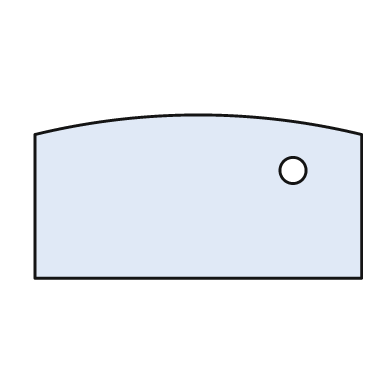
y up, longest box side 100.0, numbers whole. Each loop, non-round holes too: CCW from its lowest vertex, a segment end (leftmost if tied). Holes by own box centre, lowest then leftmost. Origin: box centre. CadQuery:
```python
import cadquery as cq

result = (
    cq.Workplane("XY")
    .moveTo(-50.0, -25.0)
    .lineTo(50.0, -25.0)
    .lineTo(50.0, 19.0)
    .threePointArc((0.0, 25.0), (-50.0, 19.0))
    .close()
    .moveTo(29.0, 8.0)
    .circle(4.0)
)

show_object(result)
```